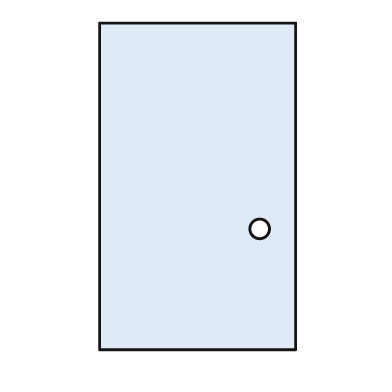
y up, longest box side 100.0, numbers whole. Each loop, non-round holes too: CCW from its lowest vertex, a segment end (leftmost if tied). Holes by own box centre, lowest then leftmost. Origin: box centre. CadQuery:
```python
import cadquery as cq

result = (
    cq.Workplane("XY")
    .moveTo(-30.0, -50.0)
    .lineTo(30.0, -50.0)
    .lineTo(30.0, 50.0)
    .lineTo(-30.0, 50.0)
    .close()
    .moveTo(19.0, -13.0)
    .circle(3.0)
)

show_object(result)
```